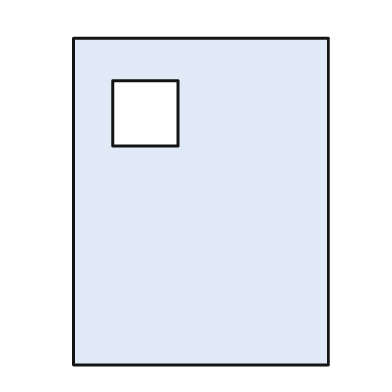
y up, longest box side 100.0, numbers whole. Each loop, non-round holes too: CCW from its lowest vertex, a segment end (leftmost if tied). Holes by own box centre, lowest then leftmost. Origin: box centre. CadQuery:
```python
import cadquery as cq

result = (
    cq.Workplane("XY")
    .moveTo(-39.0, -50.0)
    .lineTo(39.0, -50.0)
    .lineTo(39.0, 50.0)
    .lineTo(-39.0, 50.0)
    .close()
    .moveTo(-27.0, 17.0)
    .lineTo(-7.0, 17.0)
    .lineTo(-7.0, 37.0)
    .lineTo(-27.0, 37.0)
    .close()
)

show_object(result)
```